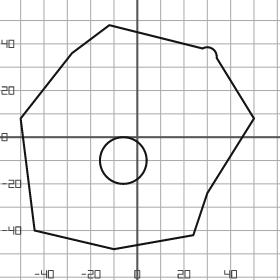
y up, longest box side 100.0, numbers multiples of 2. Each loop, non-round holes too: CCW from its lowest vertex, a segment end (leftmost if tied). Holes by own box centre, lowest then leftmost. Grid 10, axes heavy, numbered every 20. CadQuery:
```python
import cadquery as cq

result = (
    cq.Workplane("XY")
    .moveTo(-10.0, -48.0)
    .lineTo(24.0, -42.0)
    .lineTo(30.0, -24.0)
    .lineTo(50.0, 8.0)
    .lineTo(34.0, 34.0)
    .threePointArc((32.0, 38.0), (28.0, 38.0))
    .lineTo(-12.0, 48.0)
    .lineTo(-28.0, 36.0)
    .lineTo(-50.0, 8.0)
    .lineTo(-44.0, -40.0)
    .close()
    .moveTo(-6.0, -10.0)
    .circle(10.0)
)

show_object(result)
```